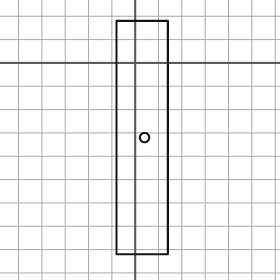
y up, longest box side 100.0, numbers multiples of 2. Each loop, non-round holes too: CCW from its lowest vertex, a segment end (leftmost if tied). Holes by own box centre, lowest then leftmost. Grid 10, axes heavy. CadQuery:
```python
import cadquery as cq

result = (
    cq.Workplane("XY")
    .moveTo(-8.0, -82.0)
    .lineTo(14.0, -82.0)
    .lineTo(14.0, 18.0)
    .lineTo(-8.0, 18.0)
    .close()
    .moveTo(4.0, -32.0)
    .circle(2.0)
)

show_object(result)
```